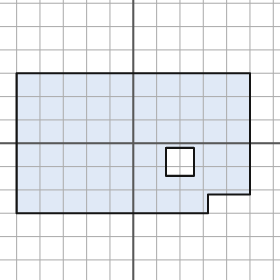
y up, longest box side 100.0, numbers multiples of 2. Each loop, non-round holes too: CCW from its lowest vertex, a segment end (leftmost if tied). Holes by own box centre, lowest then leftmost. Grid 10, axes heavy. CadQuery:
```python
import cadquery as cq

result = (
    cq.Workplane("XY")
    .moveTo(-50.0, -30.0)
    .lineTo(32.0, -30.0)
    .lineTo(32.0, -22.0)
    .lineTo(50.0, -22.0)
    .lineTo(50.0, 30.0)
    .lineTo(-50.0, 30.0)
    .close()
    .moveTo(14.0, -14.0)
    .lineTo(26.0, -14.0)
    .lineTo(26.0, -2.0)
    .lineTo(14.0, -2.0)
    .close()
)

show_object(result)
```